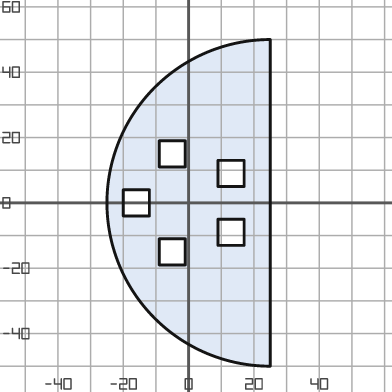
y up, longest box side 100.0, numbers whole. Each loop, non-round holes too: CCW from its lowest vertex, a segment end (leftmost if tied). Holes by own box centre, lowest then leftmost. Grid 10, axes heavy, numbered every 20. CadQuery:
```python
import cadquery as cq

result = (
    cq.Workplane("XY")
    .moveTo(25.0, -50.0)
    .lineTo(25.0, 50.0)
    .threePointArc((-25.0, 0.0), (25.0, -50.0))
    .close()
    .moveTo(-9.0, -19.0)
    .lineTo(-1.0, -19.0)
    .lineTo(-1.0, -11.0)
    .lineTo(-9.0, -11.0)
    .close()
    .moveTo(9.0, -13.0)
    .lineTo(17.0, -13.0)
    .lineTo(17.0, -5.0)
    .lineTo(9.0, -5.0)
    .close()
    .moveTo(-20.0, -4.0)
    .lineTo(-12.0, -4.0)
    .lineTo(-12.0, 4.0)
    .lineTo(-20.0, 4.0)
    .close()
    .moveTo(9.0, 5.0)
    .lineTo(17.0, 5.0)
    .lineTo(17.0, 13.0)
    .lineTo(9.0, 13.0)
    .close()
    .moveTo(-9.0, 11.0)
    .lineTo(-1.0, 11.0)
    .lineTo(-1.0, 19.0)
    .lineTo(-9.0, 19.0)
    .close()
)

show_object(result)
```